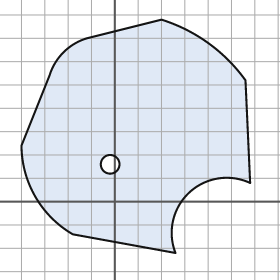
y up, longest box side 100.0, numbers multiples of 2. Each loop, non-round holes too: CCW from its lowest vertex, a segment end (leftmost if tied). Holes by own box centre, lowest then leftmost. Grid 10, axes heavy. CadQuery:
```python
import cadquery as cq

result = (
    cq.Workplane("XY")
    .moveTo(26.0, -22.0)
    .threePointArc((32.0, 4.0), (58.0, 8.0))
    .lineTo(56.0, 52.0)
    .threePointArc((40.0, 68.0), (20.0, 78.0))
    .lineTo(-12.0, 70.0)
    .threePointArc((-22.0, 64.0), (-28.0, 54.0))
    .lineTo(-40.0, 24.0)
    .threePointArc((-34.0, 2.0), (-18.0, -14.0))
    .close()
    .moveTo(-2.0, 16.0)
    .circle(4.0)
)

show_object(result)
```